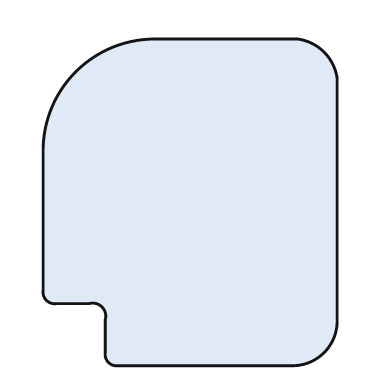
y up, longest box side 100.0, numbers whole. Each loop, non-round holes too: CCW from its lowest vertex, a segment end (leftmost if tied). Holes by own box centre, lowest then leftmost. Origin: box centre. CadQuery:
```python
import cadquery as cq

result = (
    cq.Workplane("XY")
    .moveTo(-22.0, -50.0)
    .lineTo(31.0, -50.0)
    .threePointArc((41.0, -46.0), (45.0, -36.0))
    .lineTo(45.0, 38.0)
    .threePointArc((41.0, 46.0), (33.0, 50.0))
    .lineTo(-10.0, 50.0)
    .threePointArc((-35.0, 40.0), (-45.0, 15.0))
    .lineTo(-45.0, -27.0)
    .threePointArc((-44.0, -30.0), (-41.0, -31.0))
    .lineTo(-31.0, -31.0)
    .threePointArc((-27.0, -32.0), (-26.0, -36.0))
    .lineTo(-26.0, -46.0)
    .threePointArc((-25.0, -49.0), (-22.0, -50.0))
    .close()
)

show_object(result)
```